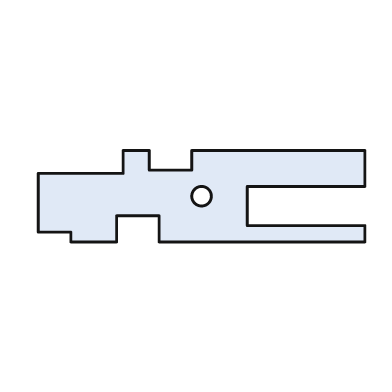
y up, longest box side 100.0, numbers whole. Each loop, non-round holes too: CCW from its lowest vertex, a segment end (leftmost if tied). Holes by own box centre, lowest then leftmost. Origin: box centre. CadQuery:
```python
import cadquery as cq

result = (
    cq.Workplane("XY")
    .moveTo(-40.0, -14.0)
    .lineTo(-26.0, -14.0)
    .lineTo(-26.0, -6.0)
    .lineTo(-13.0, -6.0)
    .lineTo(-13.0, -14.0)
    .lineTo(50.0, -14.0)
    .lineTo(50.0, -9.0)
    .lineTo(14.0, -9.0)
    .lineTo(14.0, 3.0)
    .lineTo(50.0, 3.0)
    .lineTo(50.0, 14.0)
    .lineTo(-3.0, 14.0)
    .lineTo(-3.0, 8.0)
    .lineTo(-16.0, 8.0)
    .lineTo(-16.0, 14.0)
    .lineTo(-24.0, 14.0)
    .lineTo(-24.0, 7.0)
    .lineTo(-50.0, 7.0)
    .lineTo(-50.0, -11.0)
    .lineTo(-40.0, -11.0)
    .close()
    .moveTo(0.0, 0.0)
    .circle(3.0)
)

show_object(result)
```